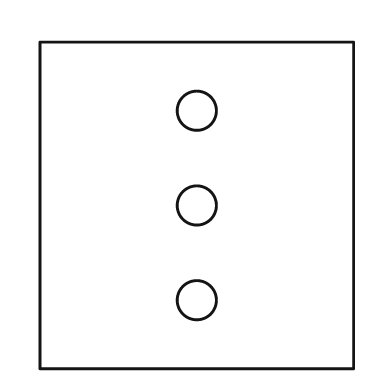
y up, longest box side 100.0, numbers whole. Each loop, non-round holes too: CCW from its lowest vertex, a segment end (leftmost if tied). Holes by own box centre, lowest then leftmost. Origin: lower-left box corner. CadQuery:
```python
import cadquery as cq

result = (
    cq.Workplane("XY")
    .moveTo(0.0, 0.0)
    .lineTo(96.0, 0.0)
    .lineTo(96.0, 100.0)
    .lineTo(0.0, 100.0)
    .close()
    .moveTo(48.0, 21.0)
    .circle(6.0)
    .moveTo(48.0, 50.0)
    .circle(6.0)
    .moveTo(48.0, 79.0)
    .circle(6.0)
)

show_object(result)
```